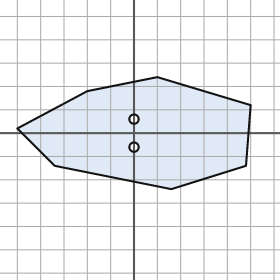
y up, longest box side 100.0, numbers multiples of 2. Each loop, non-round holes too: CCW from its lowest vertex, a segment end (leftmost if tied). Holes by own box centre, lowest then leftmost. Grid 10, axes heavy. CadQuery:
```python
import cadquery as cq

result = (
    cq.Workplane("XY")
    .moveTo(16.0, -24.0)
    .lineTo(48.0, -14.0)
    .lineTo(50.0, 12.0)
    .lineTo(10.0, 24.0)
    .lineTo(-20.0, 18.0)
    .lineTo(-50.0, 2.0)
    .lineTo(-34.0, -14.0)
    .close()
    .moveTo(0.0, -6.0)
    .circle(2.0)
    .moveTo(0.0, 6.0)
    .circle(2.0)
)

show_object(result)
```